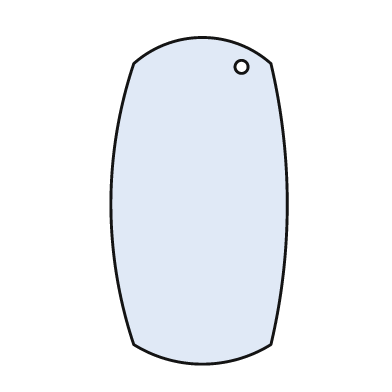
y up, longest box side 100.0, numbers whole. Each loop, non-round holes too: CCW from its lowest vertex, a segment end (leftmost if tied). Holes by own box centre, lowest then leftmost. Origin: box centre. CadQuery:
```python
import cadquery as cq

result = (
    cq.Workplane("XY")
    .moveTo(-20.0, -44.0)
    .threePointArc((1.0, -50.0), (22.0, -44.0))
    .threePointArc((27.0, -1.0), (22.0, 42.0))
    .threePointArc((1.0, 50.0), (-20.0, 42.0))
    .threePointArc((-27.0, -1.0), (-20.0, -44.0))
    .close()
    .moveTo(13.0, 41.0)
    .circle(2.0)
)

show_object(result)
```